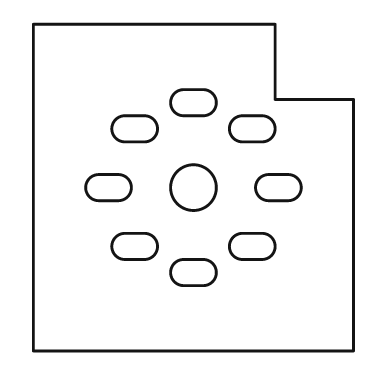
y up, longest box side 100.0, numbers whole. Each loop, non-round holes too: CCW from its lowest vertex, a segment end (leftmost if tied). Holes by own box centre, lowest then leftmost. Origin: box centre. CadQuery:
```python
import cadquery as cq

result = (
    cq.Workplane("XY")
    .moveTo(-49.0, -50.0)
    .lineTo(49.0, -50.0)
    .lineTo(49.0, 27.0)
    .lineTo(25.0, 27.0)
    .lineTo(25.0, 50.0)
    .lineTo(-49.0, 50.0)
    .close()
    .moveTo(-3.0, -30.0)
    .lineTo(3.0, -30.0)
    .threePointArc((7.0, -26.0), (3.0, -22.0))
    .lineTo(-3.0, -22.0)
    .threePointArc((-7.0, -26.0), (-3.0, -30.0))
    .close()
    .moveTo(-21.0, -22.0)
    .lineTo(-15.0, -22.0)
    .threePointArc((-11.0, -18.0), (-15.0, -14.0))
    .lineTo(-21.0, -14.0)
    .threePointArc((-25.0, -18.0), (-21.0, -22.0))
    .close()
    .moveTo(15.0, -22.0)
    .lineTo(21.0, -22.0)
    .threePointArc((25.0, -18.0), (21.0, -14.0))
    .lineTo(15.0, -14.0)
    .threePointArc((11.0, -18.0), (15.0, -22.0))
    .close()
    .moveTo(-29.0, -4.0)
    .lineTo(-23.0, -4.0)
    .threePointArc((-19.0, 0.0), (-23.0, 4.0))
    .lineTo(-29.0, 4.0)
    .threePointArc((-33.0, 0.0), (-29.0, -4.0))
    .close()
    .moveTo(0.0, 0.0)
    .circle(7.0)
    .moveTo(23.0, -4.0)
    .lineTo(29.0, -4.0)
    .threePointArc((33.0, 0.0), (29.0, 4.0))
    .lineTo(23.0, 4.0)
    .threePointArc((19.0, 0.0), (23.0, -4.0))
    .close()
    .moveTo(-21.0, 14.0)
    .lineTo(-15.0, 14.0)
    .threePointArc((-11.0, 18.0), (-15.0, 22.0))
    .lineTo(-21.0, 22.0)
    .threePointArc((-25.0, 18.0), (-21.0, 14.0))
    .close()
    .moveTo(15.0, 14.0)
    .lineTo(21.0, 14.0)
    .threePointArc((25.0, 18.0), (21.0, 22.0))
    .lineTo(15.0, 22.0)
    .threePointArc((11.0, 18.0), (15.0, 14.0))
    .close()
    .moveTo(-3.0, 22.0)
    .lineTo(3.0, 22.0)
    .threePointArc((7.0, 26.0), (3.0, 30.0))
    .lineTo(-3.0, 30.0)
    .threePointArc((-7.0, 26.0), (-3.0, 22.0))
    .close()
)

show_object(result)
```